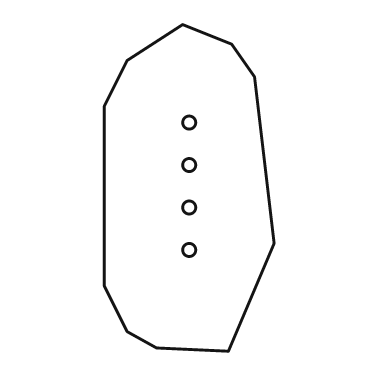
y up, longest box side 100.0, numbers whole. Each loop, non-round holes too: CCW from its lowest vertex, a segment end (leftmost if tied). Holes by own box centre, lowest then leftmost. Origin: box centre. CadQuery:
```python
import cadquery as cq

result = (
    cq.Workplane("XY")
    .moveTo(12.0, -50.0)
    .lineTo(26.0, -17.0)
    .lineTo(20.0, 34.0)
    .lineTo(13.0, 44.0)
    .lineTo(-2.0, 50.0)
    .lineTo(-19.0, 39.0)
    .lineTo(-26.0, 25.0)
    .lineTo(-26.0, -30.0)
    .lineTo(-19.0, -44.0)
    .lineTo(-10.0, -49.0)
    .close()
    .moveTo(0.0, -19.0)
    .circle(2.0)
    .moveTo(0.0, -6.0)
    .circle(2.0)
    .moveTo(0.0, 7.0)
    .circle(2.0)
    .moveTo(0.0, 20.0)
    .circle(2.0)
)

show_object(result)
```